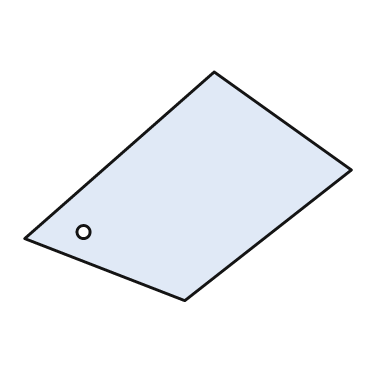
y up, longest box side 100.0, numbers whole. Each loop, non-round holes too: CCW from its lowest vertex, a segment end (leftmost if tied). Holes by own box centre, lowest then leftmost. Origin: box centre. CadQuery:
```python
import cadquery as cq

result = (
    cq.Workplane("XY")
    .moveTo(-1.0, -35.0)
    .lineTo(50.0, 5.0)
    .lineTo(8.0, 35.0)
    .lineTo(-50.0, -16.0)
    .close()
    .moveTo(-32.0, -14.0)
    .circle(2.0)
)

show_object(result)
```